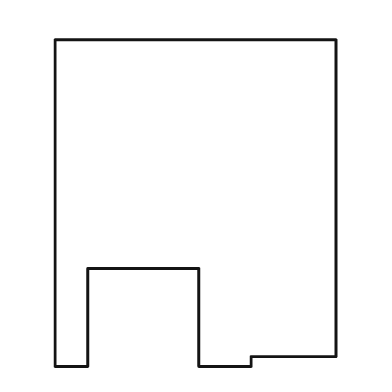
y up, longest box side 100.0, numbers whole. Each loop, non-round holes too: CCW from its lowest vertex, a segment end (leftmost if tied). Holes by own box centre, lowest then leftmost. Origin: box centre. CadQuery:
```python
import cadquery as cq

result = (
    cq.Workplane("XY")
    .moveTo(-43.0, -50.0)
    .lineTo(-33.0, -50.0)
    .lineTo(-33.0, -20.0)
    .lineTo(1.0, -20.0)
    .lineTo(1.0, -50.0)
    .lineTo(17.0, -50.0)
    .lineTo(17.0, -47.0)
    .lineTo(43.0, -47.0)
    .lineTo(43.0, 50.0)
    .lineTo(-43.0, 50.0)
    .close()
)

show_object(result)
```